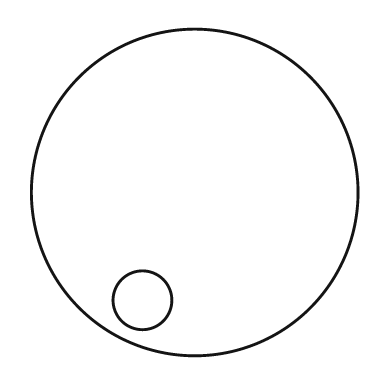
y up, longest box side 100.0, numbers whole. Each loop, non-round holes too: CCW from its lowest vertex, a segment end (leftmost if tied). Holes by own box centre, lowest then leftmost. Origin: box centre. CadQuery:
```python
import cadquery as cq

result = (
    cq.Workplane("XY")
    .moveTo(0.0, 0.0)
    .circle(50.0)
    .moveTo(-16.0, -33.0)
    .circle(9.0)
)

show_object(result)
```